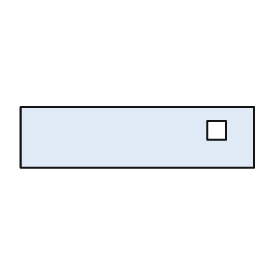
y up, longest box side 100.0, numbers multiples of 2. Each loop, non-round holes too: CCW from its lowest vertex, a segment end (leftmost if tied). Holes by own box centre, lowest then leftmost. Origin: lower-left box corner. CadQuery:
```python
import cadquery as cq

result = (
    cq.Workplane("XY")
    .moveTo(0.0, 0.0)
    .lineTo(100.0, 0.0)
    .lineTo(100.0, 26.0)
    .lineTo(0.0, 26.0)
    .close()
    .moveTo(80.0, 12.0)
    .lineTo(88.0, 12.0)
    .lineTo(88.0, 20.0)
    .lineTo(80.0, 20.0)
    .close()
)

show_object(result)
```